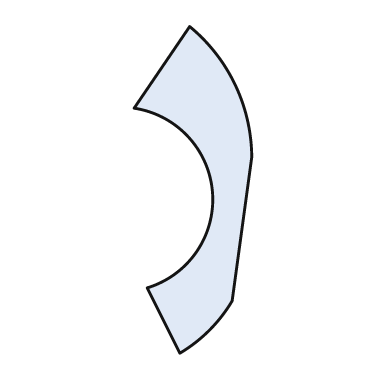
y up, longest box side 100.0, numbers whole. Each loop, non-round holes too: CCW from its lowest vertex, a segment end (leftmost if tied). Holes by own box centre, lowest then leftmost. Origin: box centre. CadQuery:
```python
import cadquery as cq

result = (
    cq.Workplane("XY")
    .moveTo(-4.0, -50.0)
    .threePointArc((5.0, -43.0), (12.0, -34.0))
    .lineTo(18.0, 10.0)
    .threePointArc((13.0, 32.0), (-1.0, 50.0))
    .lineTo(-18.0, 25.0)
    .threePointArc((6.0, -1.0), (-14.0, -30.0))
    .close()
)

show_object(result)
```